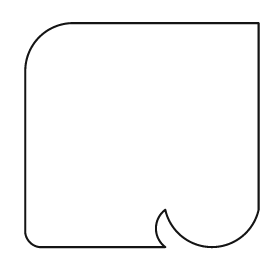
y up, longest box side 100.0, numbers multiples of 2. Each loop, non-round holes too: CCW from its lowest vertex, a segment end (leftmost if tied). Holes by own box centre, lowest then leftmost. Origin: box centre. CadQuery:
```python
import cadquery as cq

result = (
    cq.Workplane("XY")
    .moveTo(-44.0, -48.0)
    .lineTo(10.0, -48.0)
    .threePointArc((6.0, -40.0), (10.0, -32.0))
    .threePointArc((30.0, -48.0), (50.0, -32.0))
    .lineTo(50.0, 48.0)
    .lineTo(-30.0, 48.0)
    .threePointArc((-44.0, 42.0), (-50.0, 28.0))
    .lineTo(-50.0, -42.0)
    .threePointArc((-48.0, -46.0), (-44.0, -48.0))
    .close()
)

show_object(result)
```